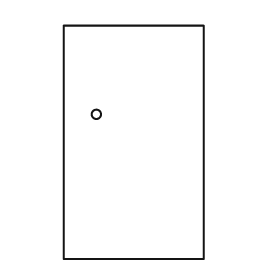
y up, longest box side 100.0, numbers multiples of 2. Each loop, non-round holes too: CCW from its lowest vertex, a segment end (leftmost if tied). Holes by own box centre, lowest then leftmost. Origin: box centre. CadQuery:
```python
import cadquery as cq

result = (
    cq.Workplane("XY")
    .moveTo(-30.0, -50.0)
    .lineTo(30.0, -50.0)
    .lineTo(30.0, 50.0)
    .lineTo(-30.0, 50.0)
    .close()
    .moveTo(-16.0, 12.0)
    .circle(2.0)
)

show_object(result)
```